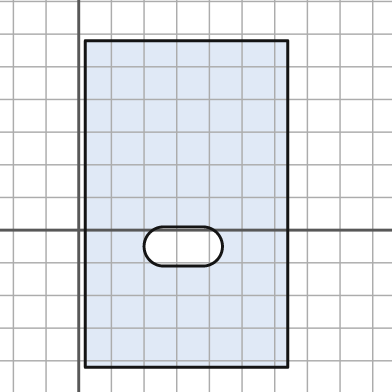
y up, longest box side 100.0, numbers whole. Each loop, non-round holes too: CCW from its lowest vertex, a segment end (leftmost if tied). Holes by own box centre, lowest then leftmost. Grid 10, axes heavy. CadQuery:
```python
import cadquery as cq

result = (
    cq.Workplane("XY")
    .moveTo(2.0, -42.0)
    .lineTo(64.0, -42.0)
    .lineTo(64.0, 58.0)
    .lineTo(2.0, 58.0)
    .close()
    .moveTo(26.0, -11.0)
    .lineTo(38.0, -11.0)
    .threePointArc((44.0, -5.0), (38.0, 1.0))
    .lineTo(26.0, 1.0)
    .threePointArc((20.0, -5.0), (26.0, -11.0))
    .close()
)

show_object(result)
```